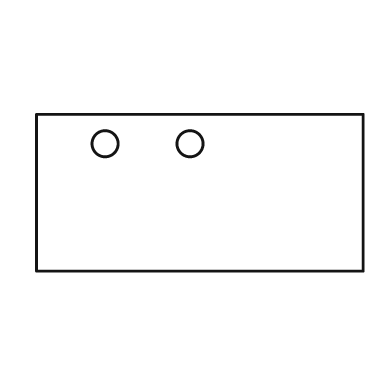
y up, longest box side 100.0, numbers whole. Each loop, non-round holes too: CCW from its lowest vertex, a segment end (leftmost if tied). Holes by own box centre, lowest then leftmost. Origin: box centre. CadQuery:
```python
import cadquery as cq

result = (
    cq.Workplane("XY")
    .moveTo(-50.0, -24.0)
    .lineTo(50.0, -24.0)
    .lineTo(50.0, 24.0)
    .lineTo(-50.0, 24.0)
    .close()
    .moveTo(-29.0, 15.0)
    .circle(4.0)
    .moveTo(-3.0, 15.0)
    .circle(4.0)
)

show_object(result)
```